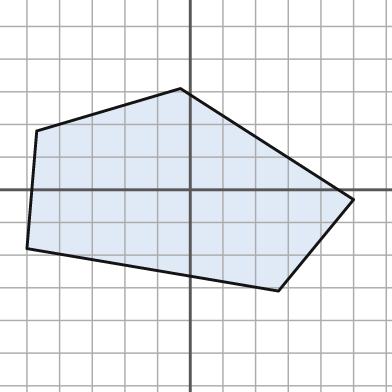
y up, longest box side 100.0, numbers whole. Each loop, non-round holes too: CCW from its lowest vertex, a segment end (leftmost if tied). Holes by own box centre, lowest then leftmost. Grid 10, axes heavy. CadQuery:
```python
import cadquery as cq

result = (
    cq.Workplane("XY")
    .moveTo(27.0, -31.0)
    .lineTo(50.0, -3.0)
    .lineTo(-3.0, 31.0)
    .lineTo(-47.0, 18.0)
    .lineTo(-50.0, -18.0)
    .close()
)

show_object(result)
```